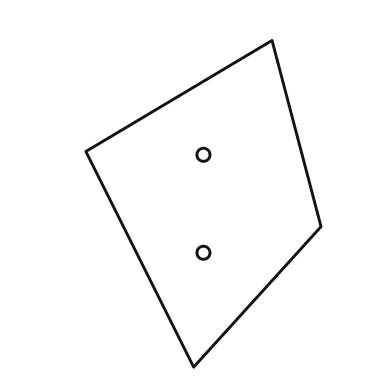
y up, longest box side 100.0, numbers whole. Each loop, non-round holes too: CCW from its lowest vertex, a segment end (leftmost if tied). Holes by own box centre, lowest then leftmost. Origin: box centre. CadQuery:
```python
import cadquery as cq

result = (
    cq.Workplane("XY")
    .moveTo(-3.0, -50.0)
    .lineTo(36.0, -7.0)
    .lineTo(21.0, 50.0)
    .lineTo(-36.0, 16.0)
    .close()
    .moveTo(0.0, -15.0)
    .circle(2.0)
    .moveTo(0.0, 15.0)
    .circle(2.0)
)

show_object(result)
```